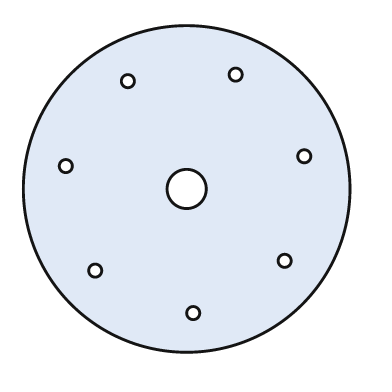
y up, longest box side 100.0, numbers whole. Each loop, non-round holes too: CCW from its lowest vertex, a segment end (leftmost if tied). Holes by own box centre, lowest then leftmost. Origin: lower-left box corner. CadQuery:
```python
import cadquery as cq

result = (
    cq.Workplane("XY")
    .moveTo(50.0, 50.0)
    .circle(50.0)
    .moveTo(52.0, 12.0)
    .circle(2.0)
    .moveTo(22.0, 25.0)
    .circle(2.0)
    .moveTo(80.0, 28.0)
    .circle(2.0)
    .moveTo(50.0, 50.0)
    .circle(6.0)
    .moveTo(13.0, 57.0)
    .circle(2.0)
    .moveTo(86.0, 60.0)
    .circle(2.0)
    .moveTo(32.0, 83.0)
    .circle(2.0)
    .moveTo(65.0, 85.0)
    .circle(2.0)
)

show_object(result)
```